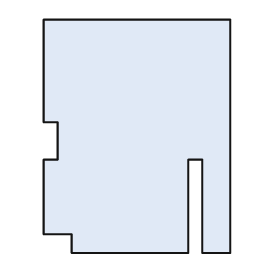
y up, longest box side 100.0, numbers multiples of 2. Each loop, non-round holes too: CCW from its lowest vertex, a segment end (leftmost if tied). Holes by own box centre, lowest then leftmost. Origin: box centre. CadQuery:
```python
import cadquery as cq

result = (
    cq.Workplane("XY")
    .moveTo(-28.0, -50.0)
    .lineTo(22.0, -50.0)
    .lineTo(22.0, -10.0)
    .lineTo(28.0, -10.0)
    .lineTo(28.0, -50.0)
    .lineTo(40.0, -50.0)
    .lineTo(40.0, 50.0)
    .lineTo(-40.0, 50.0)
    .lineTo(-40.0, 6.0)
    .lineTo(-34.0, 6.0)
    .lineTo(-34.0, -10.0)
    .lineTo(-40.0, -10.0)
    .lineTo(-40.0, -42.0)
    .lineTo(-28.0, -42.0)
    .close()
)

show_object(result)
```